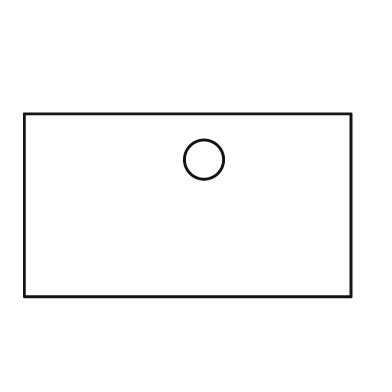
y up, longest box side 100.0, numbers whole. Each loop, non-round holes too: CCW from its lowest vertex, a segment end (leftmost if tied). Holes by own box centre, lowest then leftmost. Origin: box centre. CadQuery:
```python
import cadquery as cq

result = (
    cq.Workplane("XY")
    .moveTo(-50.0, -28.0)
    .lineTo(50.0, -28.0)
    .lineTo(50.0, 28.0)
    .lineTo(-50.0, 28.0)
    .close()
    .moveTo(5.0, 14.0)
    .circle(6.0)
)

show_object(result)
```